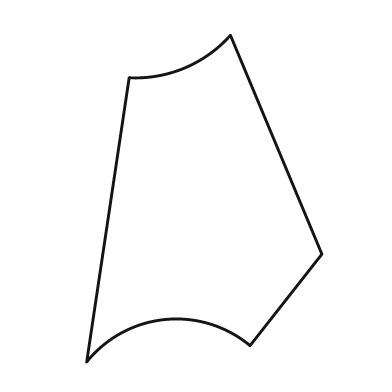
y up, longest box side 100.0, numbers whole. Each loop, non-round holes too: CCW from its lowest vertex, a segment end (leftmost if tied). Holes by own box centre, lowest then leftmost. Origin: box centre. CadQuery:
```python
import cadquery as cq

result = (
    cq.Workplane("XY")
    .moveTo(-36.0, -50.0)
    .threePointArc((-12.0, -37.0), (14.0, -45.0))
    .lineTo(36.0, -17.0)
    .lineTo(8.0, 50.0)
    .threePointArc((-6.0, 40.0), (-23.0, 37.0))
    .close()
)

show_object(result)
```